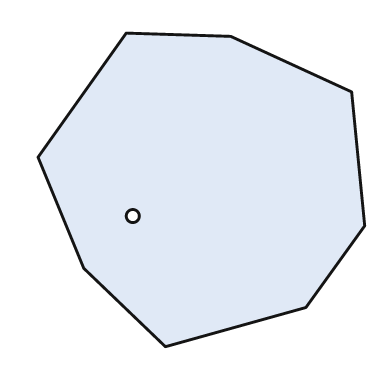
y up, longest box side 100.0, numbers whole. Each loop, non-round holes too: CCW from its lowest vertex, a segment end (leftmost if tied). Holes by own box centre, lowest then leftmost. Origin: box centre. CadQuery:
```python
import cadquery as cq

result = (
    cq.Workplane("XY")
    .moveTo(-11.0, -48.0)
    .lineTo(32.0, -36.0)
    .lineTo(50.0, -11.0)
    .lineTo(46.0, 30.0)
    .lineTo(9.0, 47.0)
    .lineTo(-23.0, 48.0)
    .lineTo(-50.0, 10.0)
    .lineTo(-36.0, -24.0)
    .close()
    .moveTo(-21.0, -8.0)
    .circle(2.0)
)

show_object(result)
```